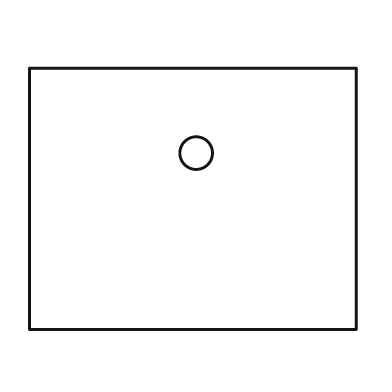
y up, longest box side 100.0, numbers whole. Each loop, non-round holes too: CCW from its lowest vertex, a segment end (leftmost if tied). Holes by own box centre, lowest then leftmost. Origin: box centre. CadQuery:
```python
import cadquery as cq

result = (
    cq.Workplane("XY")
    .moveTo(-50.0, -40.0)
    .lineTo(50.0, -40.0)
    .lineTo(50.0, 40.0)
    .lineTo(-50.0, 40.0)
    .close()
    .moveTo(1.0, 14.0)
    .circle(5.0)
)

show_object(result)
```